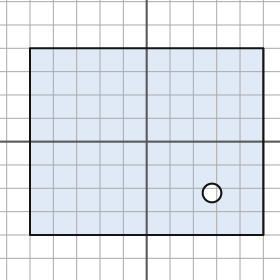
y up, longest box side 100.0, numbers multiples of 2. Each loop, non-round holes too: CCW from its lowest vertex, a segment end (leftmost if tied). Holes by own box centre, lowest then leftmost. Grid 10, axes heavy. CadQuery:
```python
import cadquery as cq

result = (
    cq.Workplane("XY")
    .moveTo(-50.0, -40.0)
    .lineTo(50.0, -40.0)
    .lineTo(50.0, 40.0)
    .lineTo(-50.0, 40.0)
    .close()
    .moveTo(28.0, -22.0)
    .circle(4.0)
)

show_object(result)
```